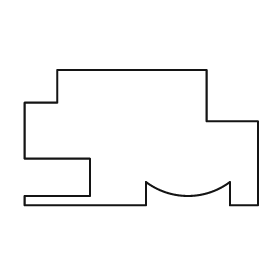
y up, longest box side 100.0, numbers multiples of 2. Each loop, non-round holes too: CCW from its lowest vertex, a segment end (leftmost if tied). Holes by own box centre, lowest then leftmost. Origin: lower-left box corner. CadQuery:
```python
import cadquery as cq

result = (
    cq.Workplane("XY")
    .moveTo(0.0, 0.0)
    .lineTo(52.0, 0.0)
    .lineTo(52.0, 10.0)
    .threePointArc((70.0, 4.0), (88.0, 10.0))
    .lineTo(88.0, 0.0)
    .lineTo(100.0, 0.0)
    .lineTo(100.0, 36.0)
    .lineTo(78.0, 36.0)
    .lineTo(78.0, 58.0)
    .lineTo(14.0, 58.0)
    .lineTo(14.0, 44.0)
    .lineTo(0.0, 44.0)
    .lineTo(0.0, 20.0)
    .lineTo(28.0, 20.0)
    .lineTo(28.0, 4.0)
    .lineTo(0.0, 4.0)
    .close()
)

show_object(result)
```